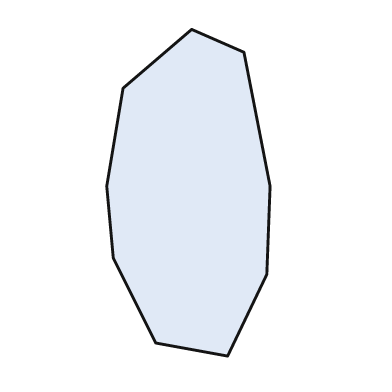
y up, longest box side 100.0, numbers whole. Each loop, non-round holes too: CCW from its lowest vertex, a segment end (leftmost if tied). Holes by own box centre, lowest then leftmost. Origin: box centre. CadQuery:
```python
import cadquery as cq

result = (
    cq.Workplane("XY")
    .moveTo(12.0, -50.0)
    .lineTo(24.0, -25.0)
    .lineTo(25.0, 2.0)
    .lineTo(17.0, 43.0)
    .lineTo(1.0, 50.0)
    .lineTo(-20.0, 32.0)
    .lineTo(-25.0, 2.0)
    .lineTo(-23.0, -20.0)
    .lineTo(-10.0, -46.0)
    .close()
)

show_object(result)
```